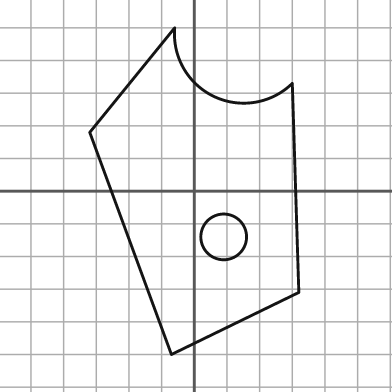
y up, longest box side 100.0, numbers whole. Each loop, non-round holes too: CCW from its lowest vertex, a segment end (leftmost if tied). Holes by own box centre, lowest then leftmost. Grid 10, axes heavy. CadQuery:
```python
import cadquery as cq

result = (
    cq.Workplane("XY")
    .moveTo(-7.0, -50.0)
    .lineTo(32.0, -31.0)
    .lineTo(30.0, 33.0)
    .threePointArc((6.0, 29.0), (-6.0, 50.0))
    .lineTo(-32.0, 18.0)
    .close()
    .moveTo(9.0, -14.0)
    .circle(7.0)
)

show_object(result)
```